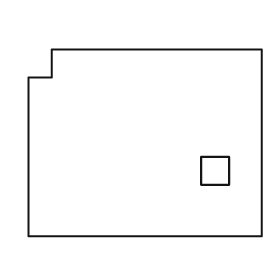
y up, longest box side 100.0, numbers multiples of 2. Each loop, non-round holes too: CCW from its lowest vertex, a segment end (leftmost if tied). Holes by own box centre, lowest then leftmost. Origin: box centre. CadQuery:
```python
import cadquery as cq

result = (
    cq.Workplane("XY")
    .moveTo(-50.0, -40.0)
    .lineTo(50.0, -40.0)
    .lineTo(50.0, 40.0)
    .lineTo(-40.0, 40.0)
    .lineTo(-40.0, 28.0)
    .lineTo(-50.0, 28.0)
    .close()
    .moveTo(24.0, -18.0)
    .lineTo(36.0, -18.0)
    .lineTo(36.0, -6.0)
    .lineTo(24.0, -6.0)
    .close()
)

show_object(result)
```